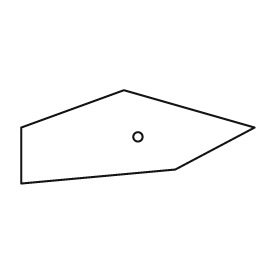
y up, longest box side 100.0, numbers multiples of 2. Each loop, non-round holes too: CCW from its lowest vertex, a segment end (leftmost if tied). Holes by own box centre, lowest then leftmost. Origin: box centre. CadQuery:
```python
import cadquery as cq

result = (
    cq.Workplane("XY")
    .moveTo(-50.0, -20.0)
    .lineTo(16.0, -14.0)
    .lineTo(50.0, 4.0)
    .lineTo(-6.0, 20.0)
    .lineTo(-50.0, 4.0)
    .close()
    .moveTo(0.0, 0.0)
    .circle(2.0)
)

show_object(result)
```